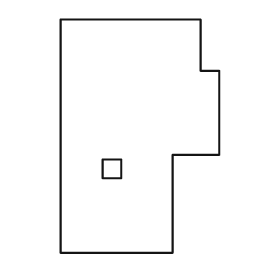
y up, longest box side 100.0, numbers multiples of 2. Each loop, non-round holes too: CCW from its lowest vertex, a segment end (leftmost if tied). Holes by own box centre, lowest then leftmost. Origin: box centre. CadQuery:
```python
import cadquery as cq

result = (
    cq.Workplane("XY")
    .moveTo(-34.0, -50.0)
    .lineTo(14.0, -50.0)
    .lineTo(14.0, -8.0)
    .lineTo(34.0, -8.0)
    .lineTo(34.0, 28.0)
    .lineTo(26.0, 28.0)
    .lineTo(26.0, 50.0)
    .lineTo(-34.0, 50.0)
    .close()
    .moveTo(-16.0, -18.0)
    .lineTo(-8.0, -18.0)
    .lineTo(-8.0, -10.0)
    .lineTo(-16.0, -10.0)
    .close()
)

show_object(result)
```